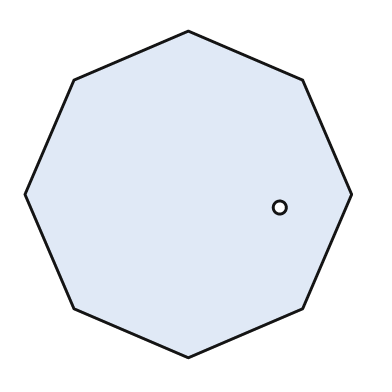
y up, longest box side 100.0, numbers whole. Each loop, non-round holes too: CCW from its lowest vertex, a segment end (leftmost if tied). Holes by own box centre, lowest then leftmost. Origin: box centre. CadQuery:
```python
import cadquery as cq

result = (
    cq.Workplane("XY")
    .moveTo(0.0, -50.0)
    .lineTo(35.0, -35.0)
    .lineTo(50.0, 0.0)
    .lineTo(35.0, 35.0)
    .lineTo(0.0, 50.0)
    .lineTo(-35.0, 35.0)
    .lineTo(-50.0, 0.0)
    .lineTo(-35.0, -35.0)
    .close()
    .moveTo(28.0, -4.0)
    .circle(2.0)
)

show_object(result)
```